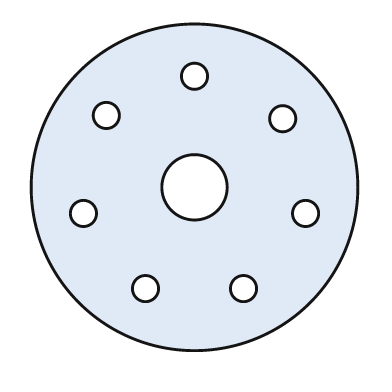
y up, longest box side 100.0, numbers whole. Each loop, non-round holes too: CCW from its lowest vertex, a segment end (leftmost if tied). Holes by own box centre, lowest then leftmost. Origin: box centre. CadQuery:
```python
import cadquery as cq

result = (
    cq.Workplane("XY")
    .moveTo(0.0, 0.0)
    .circle(50.0)
    .moveTo(-15.0, -31.0)
    .circle(4.0)
    .moveTo(15.0, -31.0)
    .circle(4.0)
    .moveTo(-34.0, -8.0)
    .circle(4.0)
    .moveTo(34.0, -8.0)
    .circle(4.0)
    .moveTo(0.0, 0.0)
    .circle(10.0)
    .moveTo(27.0, 21.0)
    .circle(4.0)
    .moveTo(-27.0, 22.0)
    .circle(4.0)
    .moveTo(0.0, 34.0)
    .circle(4.0)
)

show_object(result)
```